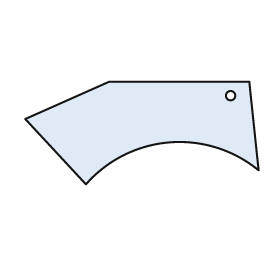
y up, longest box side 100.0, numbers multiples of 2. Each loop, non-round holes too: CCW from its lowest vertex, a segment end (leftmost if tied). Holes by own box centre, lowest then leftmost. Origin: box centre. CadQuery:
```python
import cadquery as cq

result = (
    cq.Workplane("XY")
    .moveTo(-24.0, -22.0)
    .threePointArc((12.0, -4.0), (50.0, -16.0))
    .lineTo(46.0, 22.0)
    .lineTo(-14.0, 22.0)
    .lineTo(-50.0, 6.0)
    .close()
    .moveTo(38.0, 16.0)
    .circle(2.0)
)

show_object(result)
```